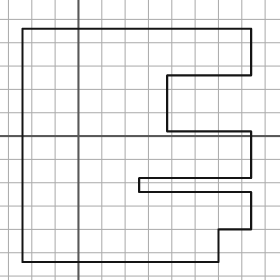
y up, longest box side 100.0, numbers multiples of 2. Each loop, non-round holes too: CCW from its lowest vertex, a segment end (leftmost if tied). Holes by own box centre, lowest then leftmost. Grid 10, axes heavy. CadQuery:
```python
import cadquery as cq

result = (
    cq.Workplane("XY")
    .moveTo(-24.0, -54.0)
    .lineTo(60.0, -54.0)
    .lineTo(60.0, -40.0)
    .lineTo(74.0, -40.0)
    .lineTo(74.0, -24.0)
    .lineTo(26.0, -24.0)
    .lineTo(26.0, -18.0)
    .lineTo(74.0, -18.0)
    .lineTo(74.0, 2.0)
    .lineTo(38.0, 2.0)
    .lineTo(38.0, 26.0)
    .lineTo(74.0, 26.0)
    .lineTo(74.0, 46.0)
    .lineTo(-24.0, 46.0)
    .close()
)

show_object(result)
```